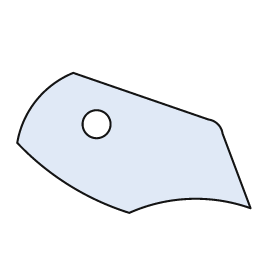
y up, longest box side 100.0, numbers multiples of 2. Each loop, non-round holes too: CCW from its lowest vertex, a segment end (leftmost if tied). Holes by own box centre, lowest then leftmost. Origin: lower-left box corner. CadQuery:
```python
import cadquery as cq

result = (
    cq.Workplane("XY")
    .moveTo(48.0, 0.0)
    .threePointArc((74.0, 6.0), (100.0, 2.0))
    .lineTo(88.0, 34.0)
    .threePointArc((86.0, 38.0), (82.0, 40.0))
    .lineTo(24.0, 60.0)
    .threePointArc((8.0, 48.0), (0.0, 30.0))
    .threePointArc((22.0, 12.0), (48.0, 0.0))
    .close()
    .moveTo(34.0, 38.0)
    .circle(6.0)
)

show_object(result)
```